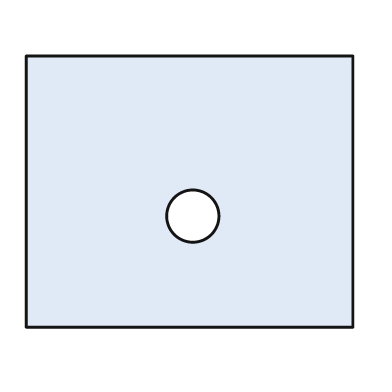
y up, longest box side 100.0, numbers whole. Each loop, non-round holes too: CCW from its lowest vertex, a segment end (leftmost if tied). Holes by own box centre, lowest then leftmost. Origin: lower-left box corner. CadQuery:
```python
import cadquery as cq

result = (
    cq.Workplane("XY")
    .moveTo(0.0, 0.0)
    .lineTo(100.0, 0.0)
    .lineTo(100.0, 83.0)
    .lineTo(0.0, 83.0)
    .close()
    .moveTo(51.0, 34.0)
    .circle(8.0)
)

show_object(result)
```